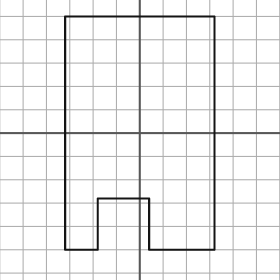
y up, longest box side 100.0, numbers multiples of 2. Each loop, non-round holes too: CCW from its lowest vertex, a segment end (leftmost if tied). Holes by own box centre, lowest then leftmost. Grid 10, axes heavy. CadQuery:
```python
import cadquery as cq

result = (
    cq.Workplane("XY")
    .moveTo(-32.0, -50.0)
    .lineTo(-18.0, -50.0)
    .lineTo(-18.0, -28.0)
    .lineTo(4.0, -28.0)
    .lineTo(4.0, -50.0)
    .lineTo(32.0, -50.0)
    .lineTo(32.0, 50.0)
    .lineTo(-32.0, 50.0)
    .close()
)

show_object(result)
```